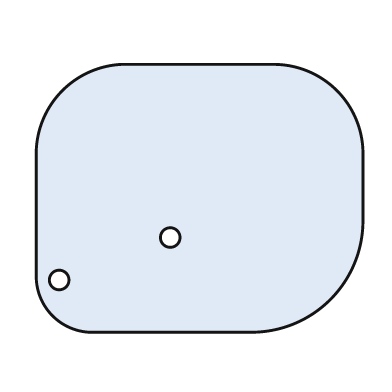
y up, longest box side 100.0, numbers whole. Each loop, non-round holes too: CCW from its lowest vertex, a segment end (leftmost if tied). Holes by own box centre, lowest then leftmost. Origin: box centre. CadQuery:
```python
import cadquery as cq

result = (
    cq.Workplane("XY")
    .moveTo(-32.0, -41.0)
    .lineTo(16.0, -41.0)
    .threePointArc((40.0, -31.0), (50.0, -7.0))
    .lineTo(50.0, 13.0)
    .threePointArc((42.0, 33.0), (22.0, 41.0))
    .lineTo(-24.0, 41.0)
    .threePointArc((-42.0, 33.0), (-50.0, 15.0))
    .lineTo(-50.0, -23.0)
    .threePointArc((-45.0, -36.0), (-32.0, -41.0))
    .close()
    .moveTo(-43.0, -25.0)
    .circle(3.0)
    .moveTo(-9.0, -12.0)
    .circle(3.0)
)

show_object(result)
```